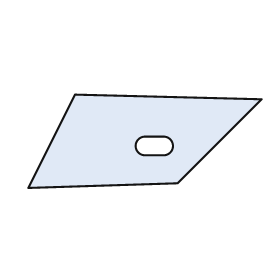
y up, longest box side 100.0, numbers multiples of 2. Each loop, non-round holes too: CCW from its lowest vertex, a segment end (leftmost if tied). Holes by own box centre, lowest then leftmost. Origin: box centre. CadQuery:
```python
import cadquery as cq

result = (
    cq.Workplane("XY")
    .moveTo(-50.0, -20.0)
    .lineTo(14.0, -18.0)
    .lineTo(50.0, 18.0)
    .lineTo(-30.0, 20.0)
    .close()
    .moveTo(0.0, -6.0)
    .lineTo(8.0, -6.0)
    .threePointArc((12.0, -2.0), (8.0, 2.0))
    .lineTo(0.0, 2.0)
    .threePointArc((-4.0, -2.0), (0.0, -6.0))
    .close()
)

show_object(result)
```